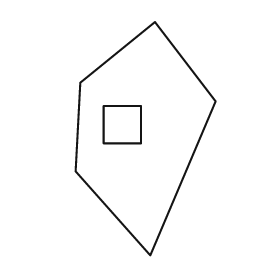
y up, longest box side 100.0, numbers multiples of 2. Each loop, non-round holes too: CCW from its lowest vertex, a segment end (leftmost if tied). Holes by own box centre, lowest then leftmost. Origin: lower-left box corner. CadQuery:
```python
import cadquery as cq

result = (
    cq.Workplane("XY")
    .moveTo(32.0, 0.0)
    .lineTo(60.0, 66.0)
    .lineTo(34.0, 100.0)
    .lineTo(2.0, 74.0)
    .lineTo(0.0, 36.0)
    .close()
    .moveTo(12.0, 48.0)
    .lineTo(28.0, 48.0)
    .lineTo(28.0, 64.0)
    .lineTo(12.0, 64.0)
    .close()
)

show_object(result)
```